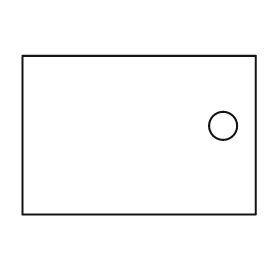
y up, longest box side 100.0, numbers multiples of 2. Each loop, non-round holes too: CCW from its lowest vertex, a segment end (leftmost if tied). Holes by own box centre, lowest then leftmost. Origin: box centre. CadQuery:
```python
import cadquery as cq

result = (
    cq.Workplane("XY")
    .moveTo(-50.0, -34.0)
    .lineTo(50.0, -34.0)
    .lineTo(50.0, 34.0)
    .lineTo(-50.0, 34.0)
    .close()
    .moveTo(36.0, 4.0)
    .circle(6.0)
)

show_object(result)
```